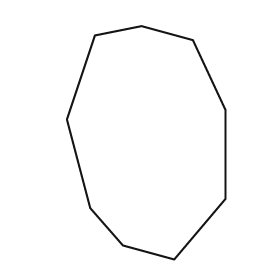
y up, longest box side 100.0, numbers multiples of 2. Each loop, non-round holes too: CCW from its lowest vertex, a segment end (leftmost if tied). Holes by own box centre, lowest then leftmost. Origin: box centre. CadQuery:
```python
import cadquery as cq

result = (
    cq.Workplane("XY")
    .moveTo(12.0, -50.0)
    .lineTo(34.0, -24.0)
    .lineTo(34.0, 14.0)
    .lineTo(20.0, 44.0)
    .lineTo(-2.0, 50.0)
    .lineTo(-22.0, 46.0)
    .lineTo(-34.0, 10.0)
    .lineTo(-24.0, -28.0)
    .lineTo(-10.0, -44.0)
    .close()
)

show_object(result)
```